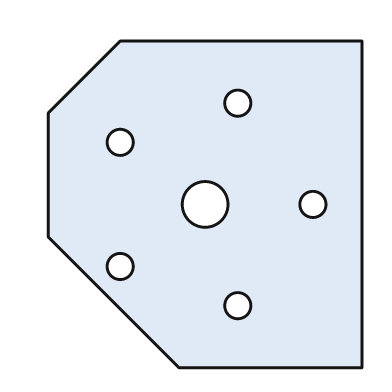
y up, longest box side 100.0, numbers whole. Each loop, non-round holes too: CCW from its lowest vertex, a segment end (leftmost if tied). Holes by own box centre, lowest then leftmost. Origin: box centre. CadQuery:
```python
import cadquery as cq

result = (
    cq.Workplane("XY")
    .moveTo(-8.0, -50.0)
    .lineTo(48.0, -50.0)
    .lineTo(48.0, 50.0)
    .lineTo(-26.0, 50.0)
    .lineTo(-48.0, 28.0)
    .lineTo(-48.0, -10.0)
    .close()
    .moveTo(10.0, -31.0)
    .circle(4.0)
    .moveTo(-26.0, -19.0)
    .circle(4.0)
    .moveTo(0.0, 0.0)
    .circle(7.0)
    .moveTo(33.0, 0.0)
    .circle(4.0)
    .moveTo(-26.0, 19.0)
    .circle(4.0)
    .moveTo(10.0, 31.0)
    .circle(4.0)
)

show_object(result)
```